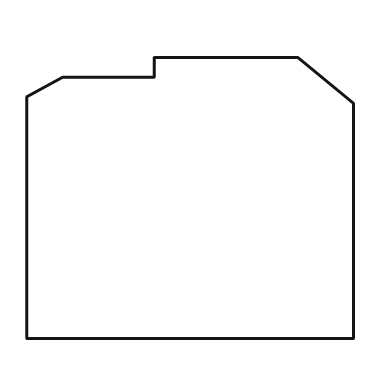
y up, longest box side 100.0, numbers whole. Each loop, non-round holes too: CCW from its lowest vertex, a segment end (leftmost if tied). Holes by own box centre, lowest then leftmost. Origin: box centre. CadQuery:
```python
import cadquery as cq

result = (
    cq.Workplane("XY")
    .moveTo(-50.0, -43.0)
    .lineTo(50.0, -43.0)
    .lineTo(50.0, 29.0)
    .lineTo(33.0, 43.0)
    .lineTo(-11.0, 43.0)
    .lineTo(-11.0, 37.0)
    .lineTo(-39.0, 37.0)
    .lineTo(-50.0, 31.0)
    .close()
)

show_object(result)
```